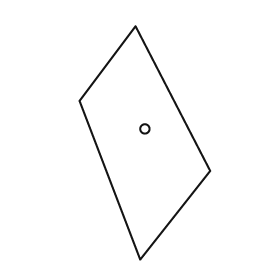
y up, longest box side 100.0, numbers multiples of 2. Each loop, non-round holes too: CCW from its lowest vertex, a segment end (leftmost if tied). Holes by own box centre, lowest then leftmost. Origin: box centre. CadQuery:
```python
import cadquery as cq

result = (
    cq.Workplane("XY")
    .moveTo(-2.0, -50.0)
    .lineTo(28.0, -12.0)
    .lineTo(-4.0, 50.0)
    .lineTo(-28.0, 18.0)
    .close()
    .moveTo(0.0, 6.0)
    .circle(2.0)
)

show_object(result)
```